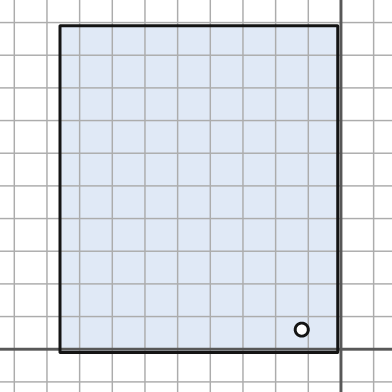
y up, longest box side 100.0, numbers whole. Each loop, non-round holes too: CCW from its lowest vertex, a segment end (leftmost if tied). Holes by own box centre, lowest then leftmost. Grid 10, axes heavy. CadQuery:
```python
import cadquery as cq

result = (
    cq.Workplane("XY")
    .moveTo(-86.0, -1.0)
    .lineTo(-1.0, -1.0)
    .lineTo(-1.0, 99.0)
    .lineTo(-86.0, 99.0)
    .close()
    .moveTo(-12.0, 6.0)
    .circle(2.0)
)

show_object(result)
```